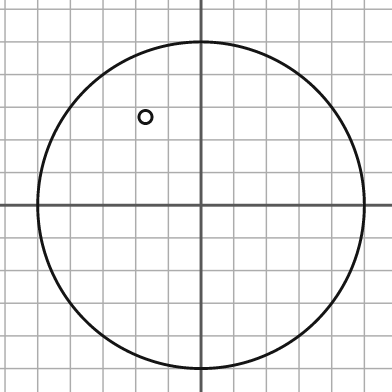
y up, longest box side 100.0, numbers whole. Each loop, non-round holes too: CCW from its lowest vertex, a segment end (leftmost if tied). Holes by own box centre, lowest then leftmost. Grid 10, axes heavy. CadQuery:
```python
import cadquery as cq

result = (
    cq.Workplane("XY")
    .moveTo(0.0, 0.0)
    .circle(50.0)
    .moveTo(-17.0, 27.0)
    .circle(2.0)
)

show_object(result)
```